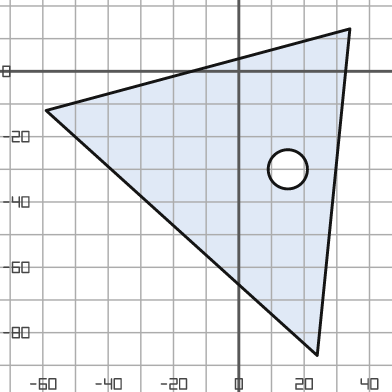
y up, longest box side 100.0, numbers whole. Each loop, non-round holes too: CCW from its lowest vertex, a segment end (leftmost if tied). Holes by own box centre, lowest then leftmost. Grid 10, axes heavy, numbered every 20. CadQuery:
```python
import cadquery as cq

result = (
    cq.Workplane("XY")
    .moveTo(24.0, -87.0)
    .lineTo(34.0, 13.0)
    .lineTo(-59.0, -12.0)
    .close()
    .moveTo(15.0, -30.0)
    .circle(6.0)
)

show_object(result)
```